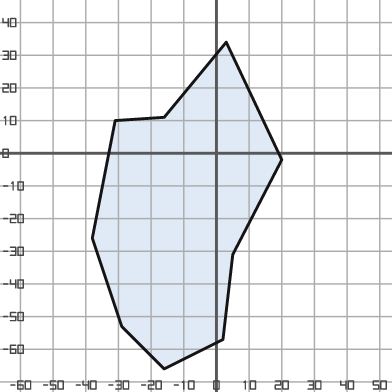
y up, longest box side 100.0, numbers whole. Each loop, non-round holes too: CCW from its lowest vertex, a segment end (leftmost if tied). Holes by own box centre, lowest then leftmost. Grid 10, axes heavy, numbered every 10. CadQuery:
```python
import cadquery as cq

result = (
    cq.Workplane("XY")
    .moveTo(-16.0, -66.0)
    .lineTo(2.0, -57.0)
    .lineTo(5.0, -31.0)
    .lineTo(20.0, -2.0)
    .lineTo(3.0, 34.0)
    .lineTo(-16.0, 11.0)
    .lineTo(-31.0, 10.0)
    .lineTo(-38.0, -26.0)
    .lineTo(-29.0, -53.0)
    .close()
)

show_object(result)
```